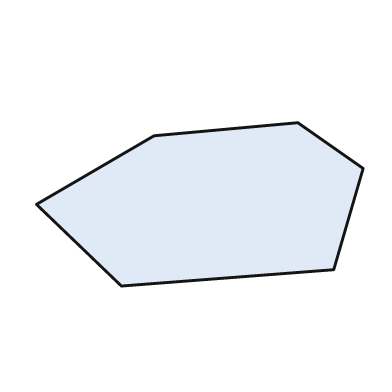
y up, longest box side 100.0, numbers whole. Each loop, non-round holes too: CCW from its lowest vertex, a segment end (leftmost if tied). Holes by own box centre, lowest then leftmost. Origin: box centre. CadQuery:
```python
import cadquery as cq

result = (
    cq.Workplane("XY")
    .moveTo(-24.0, -25.0)
    .lineTo(41.0, -20.0)
    .lineTo(50.0, 11.0)
    .lineTo(30.0, 25.0)
    .lineTo(-14.0, 21.0)
    .lineTo(-50.0, 0.0)
    .close()
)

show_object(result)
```